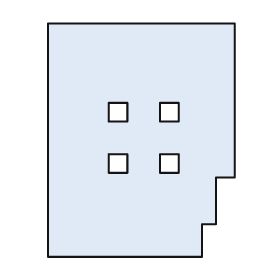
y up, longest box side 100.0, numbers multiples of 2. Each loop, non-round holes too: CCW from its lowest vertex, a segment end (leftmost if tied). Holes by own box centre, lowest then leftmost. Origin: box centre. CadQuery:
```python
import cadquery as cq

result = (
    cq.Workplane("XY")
    .moveTo(-40.0, -50.0)
    .lineTo(26.0, -50.0)
    .lineTo(26.0, -36.0)
    .lineTo(32.0, -36.0)
    .lineTo(32.0, -16.0)
    .lineTo(40.0, -16.0)
    .lineTo(40.0, 50.0)
    .lineTo(-40.0, 50.0)
    .close()
    .moveTo(-14.0, -14.0)
    .lineTo(-6.0, -14.0)
    .lineTo(-6.0, -6.0)
    .lineTo(-14.0, -6.0)
    .close()
    .moveTo(8.0, -14.0)
    .lineTo(16.0, -14.0)
    .lineTo(16.0, -6.0)
    .lineTo(8.0, -6.0)
    .close()
    .moveTo(-14.0, 8.0)
    .lineTo(-6.0, 8.0)
    .lineTo(-6.0, 16.0)
    .lineTo(-14.0, 16.0)
    .close()
    .moveTo(8.0, 8.0)
    .lineTo(16.0, 8.0)
    .lineTo(16.0, 16.0)
    .lineTo(8.0, 16.0)
    .close()
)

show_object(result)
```